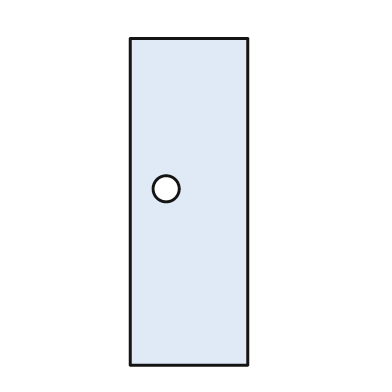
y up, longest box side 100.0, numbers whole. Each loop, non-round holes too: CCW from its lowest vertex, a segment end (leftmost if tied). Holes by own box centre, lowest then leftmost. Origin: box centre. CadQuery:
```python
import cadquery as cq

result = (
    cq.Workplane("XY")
    .moveTo(-18.0, -50.0)
    .lineTo(18.0, -50.0)
    .lineTo(18.0, 50.0)
    .lineTo(-18.0, 50.0)
    .close()
    .moveTo(-7.0, 4.0)
    .circle(4.0)
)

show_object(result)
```